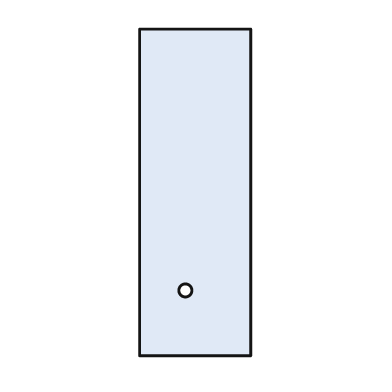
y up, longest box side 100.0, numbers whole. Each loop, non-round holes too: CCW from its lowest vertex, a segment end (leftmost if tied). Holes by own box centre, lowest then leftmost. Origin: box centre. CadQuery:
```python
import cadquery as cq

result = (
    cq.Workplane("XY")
    .moveTo(-17.0, -50.0)
    .lineTo(17.0, -50.0)
    .lineTo(17.0, 50.0)
    .lineTo(-17.0, 50.0)
    .close()
    .moveTo(-3.0, -30.0)
    .circle(2.0)
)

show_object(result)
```